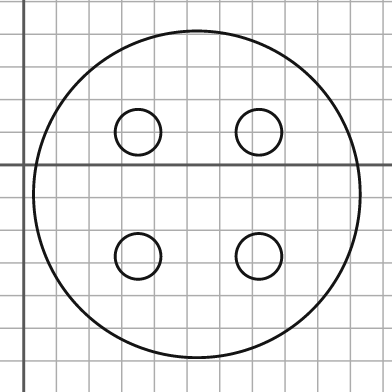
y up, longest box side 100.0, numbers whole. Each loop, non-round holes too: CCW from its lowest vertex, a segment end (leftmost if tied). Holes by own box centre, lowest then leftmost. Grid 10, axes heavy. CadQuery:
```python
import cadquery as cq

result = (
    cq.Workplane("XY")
    .moveTo(53.0, -9.0)
    .circle(50.0)
    .moveTo(35.0, -28.0)
    .circle(7.0)
    .moveTo(72.0, -28.0)
    .circle(7.0)
    .moveTo(35.0, 10.0)
    .circle(7.0)
    .moveTo(72.0, 10.0)
    .circle(7.0)
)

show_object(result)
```